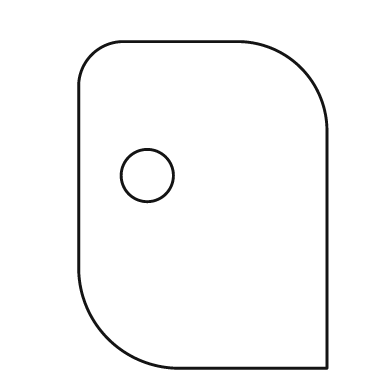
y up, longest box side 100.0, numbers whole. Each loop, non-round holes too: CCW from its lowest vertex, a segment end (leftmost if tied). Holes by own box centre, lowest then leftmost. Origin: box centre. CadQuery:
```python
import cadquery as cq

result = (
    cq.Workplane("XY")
    .moveTo(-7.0, -50.0)
    .lineTo(38.0, -50.0)
    .lineTo(38.0, 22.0)
    .threePointArc((30.0, 42.0), (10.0, 50.0))
    .lineTo(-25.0, 50.0)
    .threePointArc((-34.0, 46.0), (-38.0, 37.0))
    .lineTo(-38.0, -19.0)
    .threePointArc((-29.0, -41.0), (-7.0, -50.0))
    .close()
    .moveTo(-17.0, 9.0)
    .circle(8.0)
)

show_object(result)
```